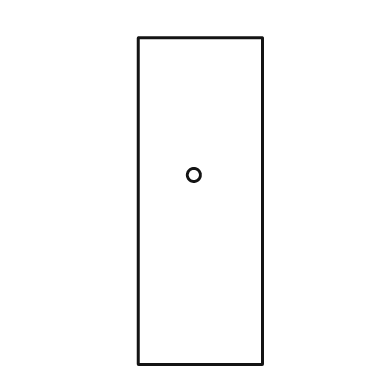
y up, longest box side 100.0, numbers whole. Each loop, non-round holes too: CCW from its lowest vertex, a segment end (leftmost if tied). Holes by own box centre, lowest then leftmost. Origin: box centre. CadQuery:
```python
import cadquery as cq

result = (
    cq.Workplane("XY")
    .moveTo(-19.0, -50.0)
    .lineTo(19.0, -50.0)
    .lineTo(19.0, 50.0)
    .lineTo(-19.0, 50.0)
    .close()
    .moveTo(-2.0, 8.0)
    .circle(2.0)
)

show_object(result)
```